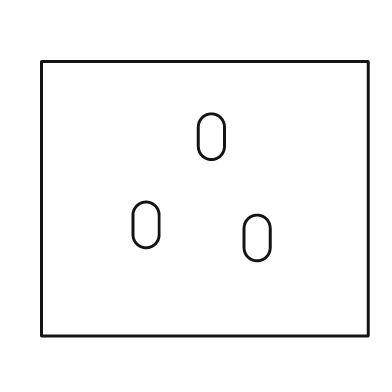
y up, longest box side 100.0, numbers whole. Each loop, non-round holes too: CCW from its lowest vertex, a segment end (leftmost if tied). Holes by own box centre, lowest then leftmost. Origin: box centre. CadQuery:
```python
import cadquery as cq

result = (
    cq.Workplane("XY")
    .moveTo(-50.0, -42.0)
    .lineTo(50.0, -42.0)
    .lineTo(50.0, 42.0)
    .lineTo(-50.0, 42.0)
    .close()
    .moveTo(12.0, -15.0)
    .threePointArc((16.0, -19.0), (20.0, -15.0))
    .lineTo(20.0, -9.0)
    .threePointArc((16.0, -5.0), (12.0, -9.0))
    .close()
    .moveTo(-22.0, -11.0)
    .threePointArc((-18.0, -15.0), (-14.0, -11.0))
    .lineTo(-14.0, -5.0)
    .threePointArc((-18.0, -1.0), (-22.0, -5.0))
    .close()
    .moveTo(-2.0, 16.0)
    .threePointArc((2.0, 12.0), (6.0, 16.0))
    .lineTo(6.0, 22.0)
    .threePointArc((2.0, 26.0), (-2.0, 22.0))
    .close()
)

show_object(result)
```